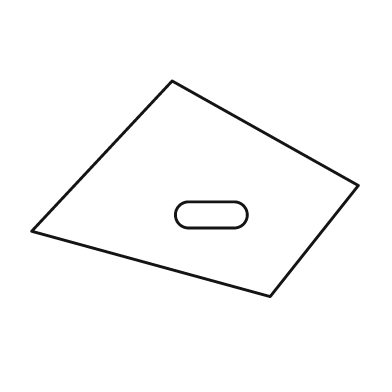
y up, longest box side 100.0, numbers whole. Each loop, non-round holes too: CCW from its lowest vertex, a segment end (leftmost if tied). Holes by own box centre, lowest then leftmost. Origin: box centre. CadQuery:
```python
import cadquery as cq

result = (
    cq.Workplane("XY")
    .moveTo(23.0, -33.0)
    .lineTo(50.0, 1.0)
    .lineTo(-7.0, 33.0)
    .lineTo(-50.0, -13.0)
    .close()
    .moveTo(-2.0, -12.0)
    .lineTo(12.0, -12.0)
    .threePointArc((16.0, -8.0), (12.0, -4.0))
    .lineTo(-2.0, -4.0)
    .threePointArc((-6.0, -8.0), (-2.0, -12.0))
    .close()
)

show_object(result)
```